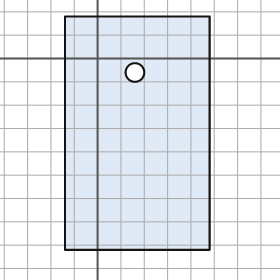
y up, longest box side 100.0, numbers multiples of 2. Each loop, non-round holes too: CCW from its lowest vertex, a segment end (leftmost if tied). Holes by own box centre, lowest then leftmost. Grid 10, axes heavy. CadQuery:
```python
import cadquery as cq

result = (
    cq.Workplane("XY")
    .moveTo(-14.0, -82.0)
    .lineTo(48.0, -82.0)
    .lineTo(48.0, 18.0)
    .lineTo(-14.0, 18.0)
    .close()
    .moveTo(16.0, -6.0)
    .circle(4.0)
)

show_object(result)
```